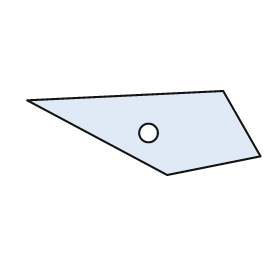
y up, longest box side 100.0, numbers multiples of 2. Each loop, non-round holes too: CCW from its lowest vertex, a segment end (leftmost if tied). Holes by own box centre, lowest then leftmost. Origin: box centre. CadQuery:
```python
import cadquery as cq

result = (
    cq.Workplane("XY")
    .moveTo(10.0, -18.0)
    .lineTo(50.0, -10.0)
    .lineTo(34.0, 18.0)
    .lineTo(-50.0, 14.0)
    .close()
    .moveTo(2.0, 0.0)
    .circle(4.0)
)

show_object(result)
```